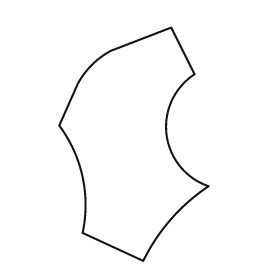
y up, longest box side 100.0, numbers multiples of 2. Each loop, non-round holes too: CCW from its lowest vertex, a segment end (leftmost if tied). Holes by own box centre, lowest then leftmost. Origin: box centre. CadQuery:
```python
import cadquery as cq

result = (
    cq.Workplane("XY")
    .moveTo(4.0, -50.0)
    .threePointArc((16.0, -32.0), (32.0, -18.0))
    .threePointArc((14.0, 4.0), (26.0, 30.0))
    .lineTo(16.0, 50.0)
    .lineTo(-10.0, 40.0)
    .threePointArc((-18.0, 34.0), (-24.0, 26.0))
    .lineTo(-32.0, 8.0)
    .threePointArc((-22.0, -14.0), (-22.0, -38.0))
    .close()
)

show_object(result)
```